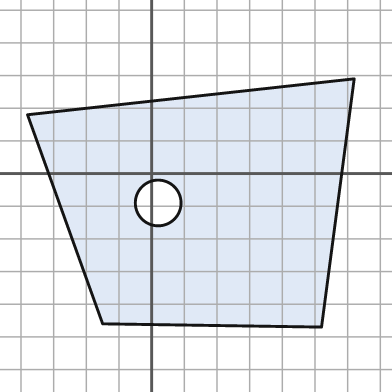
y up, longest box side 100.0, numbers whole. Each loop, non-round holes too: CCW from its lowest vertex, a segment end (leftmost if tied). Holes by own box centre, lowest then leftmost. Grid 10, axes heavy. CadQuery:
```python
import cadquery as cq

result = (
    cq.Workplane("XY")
    .moveTo(52.0, -47.0)
    .lineTo(62.0, 29.0)
    .lineTo(-38.0, 18.0)
    .lineTo(-15.0, -46.0)
    .close()
    .moveTo(2.0, -9.0)
    .circle(7.0)
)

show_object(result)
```